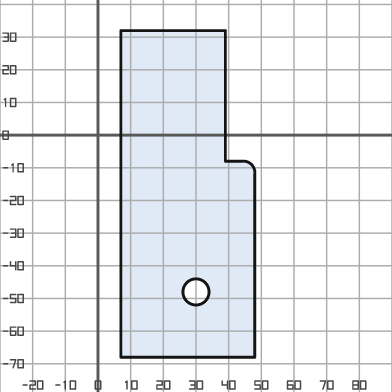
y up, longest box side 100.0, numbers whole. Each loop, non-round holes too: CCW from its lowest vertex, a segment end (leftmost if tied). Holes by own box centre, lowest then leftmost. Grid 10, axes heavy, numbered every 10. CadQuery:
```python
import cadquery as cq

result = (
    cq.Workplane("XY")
    .moveTo(7.0, -68.0)
    .lineTo(48.0, -68.0)
    .lineTo(48.0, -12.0)
    .threePointArc((47.0, -9.0), (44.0, -8.0))
    .lineTo(39.0, -8.0)
    .lineTo(39.0, 32.0)
    .lineTo(7.0, 32.0)
    .close()
    .moveTo(30.0, -48.0)
    .circle(4.0)
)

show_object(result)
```